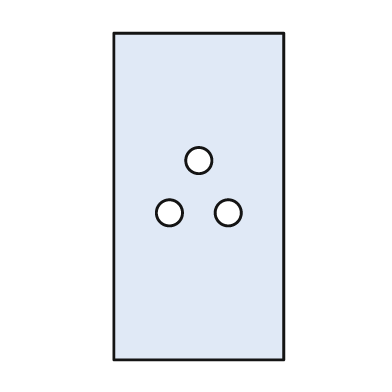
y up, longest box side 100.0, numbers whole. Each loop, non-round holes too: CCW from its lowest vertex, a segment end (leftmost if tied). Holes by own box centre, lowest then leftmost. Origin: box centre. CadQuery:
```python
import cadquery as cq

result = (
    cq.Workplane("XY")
    .moveTo(-26.0, -50.0)
    .lineTo(26.0, -50.0)
    .lineTo(26.0, 50.0)
    .lineTo(-26.0, 50.0)
    .close()
    .moveTo(-9.0, -5.0)
    .circle(4.0)
    .moveTo(9.0, -5.0)
    .circle(4.0)
    .moveTo(0.0, 11.0)
    .circle(4.0)
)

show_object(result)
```